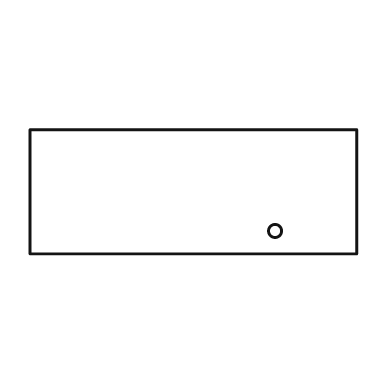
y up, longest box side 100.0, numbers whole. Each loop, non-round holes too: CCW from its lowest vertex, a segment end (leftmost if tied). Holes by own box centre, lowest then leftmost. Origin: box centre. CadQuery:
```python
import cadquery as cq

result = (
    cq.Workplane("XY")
    .moveTo(-50.0, -19.0)
    .lineTo(50.0, -19.0)
    .lineTo(50.0, 19.0)
    .lineTo(-50.0, 19.0)
    .close()
    .moveTo(25.0, -12.0)
    .circle(2.0)
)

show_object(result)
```